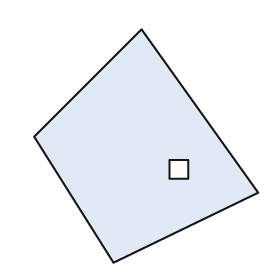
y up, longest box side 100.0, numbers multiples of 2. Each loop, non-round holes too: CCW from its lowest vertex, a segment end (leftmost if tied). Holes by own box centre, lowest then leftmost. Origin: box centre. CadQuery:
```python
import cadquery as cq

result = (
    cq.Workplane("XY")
    .moveTo(-14.0, -50.0)
    .lineTo(48.0, -20.0)
    .lineTo(-2.0, 50.0)
    .lineTo(-48.0, 4.0)
    .close()
    .moveTo(10.0, -14.0)
    .lineTo(18.0, -14.0)
    .lineTo(18.0, -6.0)
    .lineTo(10.0, -6.0)
    .close()
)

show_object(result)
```